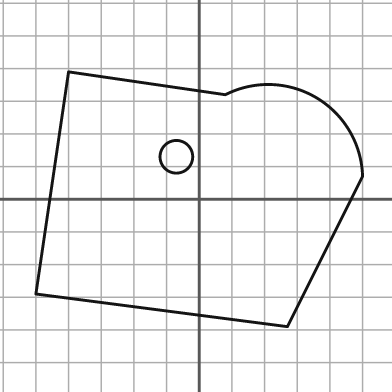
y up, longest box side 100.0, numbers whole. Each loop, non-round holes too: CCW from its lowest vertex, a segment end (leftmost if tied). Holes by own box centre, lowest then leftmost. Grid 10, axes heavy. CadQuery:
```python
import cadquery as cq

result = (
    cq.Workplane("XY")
    .moveTo(27.0, -39.0)
    .lineTo(50.0, 7.0)
    .threePointArc((36.0, 31.0), (8.0, 32.0))
    .lineTo(-40.0, 39.0)
    .lineTo(-50.0, -29.0)
    .close()
    .moveTo(-7.0, 13.0)
    .circle(5.0)
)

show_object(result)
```